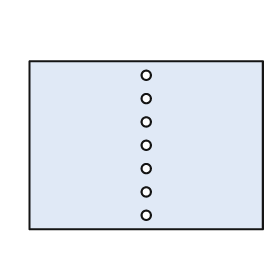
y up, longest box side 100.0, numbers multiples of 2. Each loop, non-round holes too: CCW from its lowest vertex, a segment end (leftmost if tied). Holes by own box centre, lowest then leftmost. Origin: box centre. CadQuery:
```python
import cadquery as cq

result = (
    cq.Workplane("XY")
    .moveTo(-50.0, -36.0)
    .lineTo(50.0, -36.0)
    .lineTo(50.0, 36.0)
    .lineTo(-50.0, 36.0)
    .close()
    .moveTo(0.0, -30.0)
    .circle(2.0)
    .moveTo(0.0, -20.0)
    .circle(2.0)
    .moveTo(0.0, -10.0)
    .circle(2.0)
    .moveTo(0.0, 0.0)
    .circle(2.0)
    .moveTo(0.0, 10.0)
    .circle(2.0)
    .moveTo(0.0, 20.0)
    .circle(2.0)
    .moveTo(0.0, 30.0)
    .circle(2.0)
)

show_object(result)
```